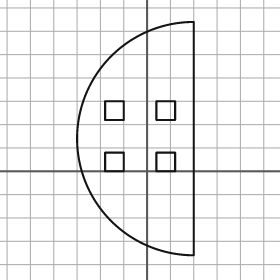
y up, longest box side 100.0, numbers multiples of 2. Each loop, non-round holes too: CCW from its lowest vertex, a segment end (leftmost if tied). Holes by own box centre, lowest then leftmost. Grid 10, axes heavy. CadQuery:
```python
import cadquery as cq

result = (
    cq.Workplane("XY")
    .moveTo(20.0, -36.0)
    .lineTo(20.0, 64.0)
    .threePointArc((-30.0, 14.0), (20.0, -36.0))
    .close()
    .moveTo(-18.0, 0.0)
    .lineTo(-10.0, 0.0)
    .lineTo(-10.0, 8.0)
    .lineTo(-18.0, 8.0)
    .close()
    .moveTo(4.0, 0.0)
    .lineTo(12.0, 0.0)
    .lineTo(12.0, 8.0)
    .lineTo(4.0, 8.0)
    .close()
    .moveTo(-18.0, 22.0)
    .lineTo(-10.0, 22.0)
    .lineTo(-10.0, 30.0)
    .lineTo(-18.0, 30.0)
    .close()
    .moveTo(4.0, 22.0)
    .lineTo(12.0, 22.0)
    .lineTo(12.0, 30.0)
    .lineTo(4.0, 30.0)
    .close()
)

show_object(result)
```